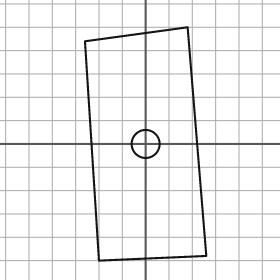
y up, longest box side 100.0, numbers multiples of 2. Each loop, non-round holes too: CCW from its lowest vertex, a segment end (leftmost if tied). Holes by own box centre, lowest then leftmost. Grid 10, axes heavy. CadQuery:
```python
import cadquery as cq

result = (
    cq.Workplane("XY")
    .moveTo(-20.0, -50.0)
    .lineTo(26.0, -48.0)
    .lineTo(18.0, 50.0)
    .lineTo(-26.0, 44.0)
    .close()
    .moveTo(0.0, 0.0)
    .circle(6.0)
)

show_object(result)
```